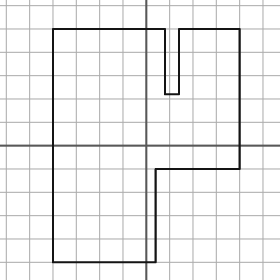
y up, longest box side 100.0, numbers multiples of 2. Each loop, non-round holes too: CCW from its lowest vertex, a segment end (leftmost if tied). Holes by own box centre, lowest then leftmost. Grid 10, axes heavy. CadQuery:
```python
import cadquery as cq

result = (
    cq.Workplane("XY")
    .moveTo(-40.0, -50.0)
    .lineTo(4.0, -50.0)
    .lineTo(4.0, -10.0)
    .lineTo(40.0, -10.0)
    .lineTo(40.0, 50.0)
    .lineTo(14.0, 50.0)
    .lineTo(14.0, 22.0)
    .lineTo(8.0, 22.0)
    .lineTo(8.0, 50.0)
    .lineTo(-40.0, 50.0)
    .close()
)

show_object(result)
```